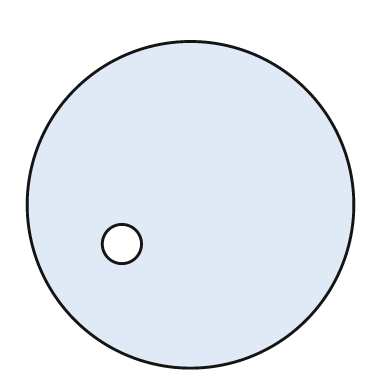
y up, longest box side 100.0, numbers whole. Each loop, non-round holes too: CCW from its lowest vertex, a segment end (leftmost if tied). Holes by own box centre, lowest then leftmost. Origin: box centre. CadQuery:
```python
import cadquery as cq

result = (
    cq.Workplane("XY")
    .moveTo(0.0, 0.0)
    .circle(50.0)
    .moveTo(-21.0, -12.0)
    .circle(6.0)
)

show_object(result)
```